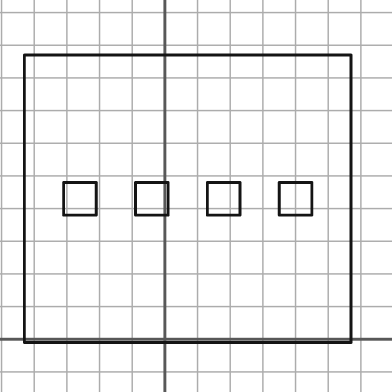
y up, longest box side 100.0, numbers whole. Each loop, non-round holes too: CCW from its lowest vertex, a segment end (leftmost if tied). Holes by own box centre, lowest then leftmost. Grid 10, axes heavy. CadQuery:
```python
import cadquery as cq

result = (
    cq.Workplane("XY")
    .moveTo(-43.0, -1.0)
    .lineTo(57.0, -1.0)
    .lineTo(57.0, 87.0)
    .lineTo(-43.0, 87.0)
    .close()
    .moveTo(-31.0, 38.0)
    .lineTo(-21.0, 38.0)
    .lineTo(-21.0, 48.0)
    .lineTo(-31.0, 48.0)
    .close()
    .moveTo(-9.0, 38.0)
    .lineTo(1.0, 38.0)
    .lineTo(1.0, 48.0)
    .lineTo(-9.0, 48.0)
    .close()
    .moveTo(13.0, 38.0)
    .lineTo(23.0, 38.0)
    .lineTo(23.0, 48.0)
    .lineTo(13.0, 48.0)
    .close()
    .moveTo(35.0, 38.0)
    .lineTo(45.0, 38.0)
    .lineTo(45.0, 48.0)
    .lineTo(35.0, 48.0)
    .close()
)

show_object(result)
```